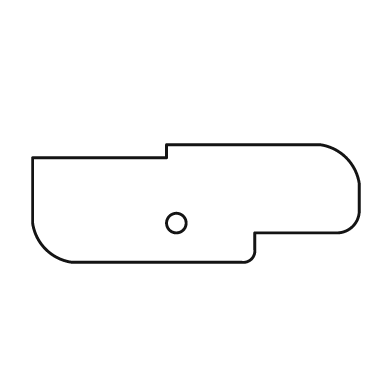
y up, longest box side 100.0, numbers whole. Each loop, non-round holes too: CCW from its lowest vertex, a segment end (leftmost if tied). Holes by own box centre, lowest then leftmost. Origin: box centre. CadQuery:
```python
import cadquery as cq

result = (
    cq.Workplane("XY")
    .moveTo(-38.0, -18.0)
    .lineTo(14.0, -18.0)
    .threePointArc((17.0, -17.0), (18.0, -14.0))
    .lineTo(18.0, -9.0)
    .lineTo(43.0, -9.0)
    .threePointArc((48.0, -7.0), (50.0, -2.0))
    .lineTo(50.0, 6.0)
    .threePointArc((46.0, 14.0), (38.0, 18.0))
    .lineTo(-9.0, 18.0)
    .lineTo(-9.0, 14.0)
    .lineTo(-50.0, 14.0)
    .lineTo(-50.0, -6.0)
    .threePointArc((-46.0, -14.0), (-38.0, -18.0))
    .close()
    .moveTo(-6.0, -6.0)
    .circle(3.0)
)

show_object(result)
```